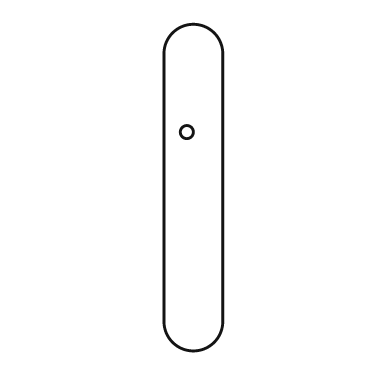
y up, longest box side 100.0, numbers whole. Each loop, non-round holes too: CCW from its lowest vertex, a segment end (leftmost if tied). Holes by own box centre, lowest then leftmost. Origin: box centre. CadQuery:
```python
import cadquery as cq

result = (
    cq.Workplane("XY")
    .moveTo(-9.0, -41.0)
    .threePointArc((0.0, -50.0), (9.0, -41.0))
    .lineTo(9.0, 41.0)
    .threePointArc((0.0, 50.0), (-9.0, 41.0))
    .close()
    .moveTo(-2.0, 17.0)
    .circle(2.0)
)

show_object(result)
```